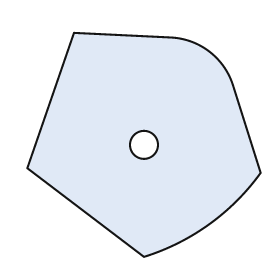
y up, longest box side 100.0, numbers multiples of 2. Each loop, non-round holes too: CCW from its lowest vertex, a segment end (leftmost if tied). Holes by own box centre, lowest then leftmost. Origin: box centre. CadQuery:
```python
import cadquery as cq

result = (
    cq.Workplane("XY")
    .moveTo(0.0, -48.0)
    .threePointArc((28.0, -34.0), (50.0, -12.0))
    .lineTo(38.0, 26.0)
    .threePointArc((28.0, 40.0), (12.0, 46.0))
    .lineTo(-30.0, 48.0)
    .lineTo(-50.0, -10.0)
    .close()
    .moveTo(0.0, 0.0)
    .circle(6.0)
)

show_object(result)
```